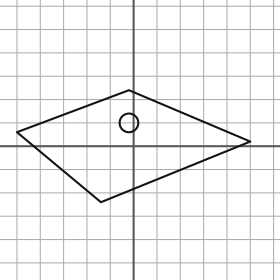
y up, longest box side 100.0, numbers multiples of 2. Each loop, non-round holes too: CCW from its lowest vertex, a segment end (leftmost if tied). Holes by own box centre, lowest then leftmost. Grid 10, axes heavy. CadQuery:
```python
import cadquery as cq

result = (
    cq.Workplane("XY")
    .moveTo(-14.0, -24.0)
    .lineTo(50.0, 2.0)
    .lineTo(-2.0, 24.0)
    .lineTo(-50.0, 6.0)
    .close()
    .moveTo(-2.0, 10.0)
    .circle(4.0)
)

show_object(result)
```